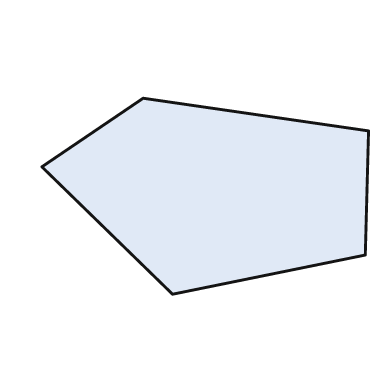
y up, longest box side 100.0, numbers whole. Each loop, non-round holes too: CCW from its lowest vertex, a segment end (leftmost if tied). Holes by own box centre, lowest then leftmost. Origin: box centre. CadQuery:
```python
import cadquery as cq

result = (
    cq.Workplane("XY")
    .moveTo(-10.0, -30.0)
    .lineTo(49.0, -18.0)
    .lineTo(50.0, 20.0)
    .lineTo(-19.0, 30.0)
    .lineTo(-50.0, 9.0)
    .close()
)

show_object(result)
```